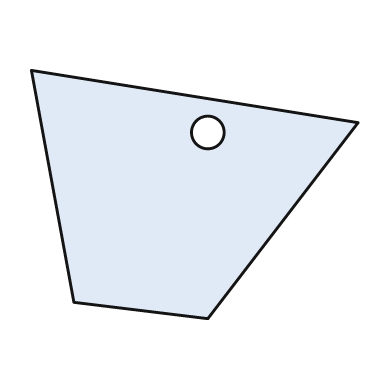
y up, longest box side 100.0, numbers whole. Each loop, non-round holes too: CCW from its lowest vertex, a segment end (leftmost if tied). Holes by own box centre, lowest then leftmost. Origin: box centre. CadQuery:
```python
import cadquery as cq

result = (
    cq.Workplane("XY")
    .moveTo(4.0, -38.0)
    .lineTo(50.0, 22.0)
    .lineTo(-50.0, 38.0)
    .lineTo(-37.0, -33.0)
    .close()
    .moveTo(4.0, 19.0)
    .circle(5.0)
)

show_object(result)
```